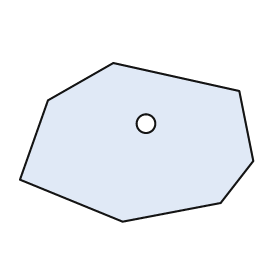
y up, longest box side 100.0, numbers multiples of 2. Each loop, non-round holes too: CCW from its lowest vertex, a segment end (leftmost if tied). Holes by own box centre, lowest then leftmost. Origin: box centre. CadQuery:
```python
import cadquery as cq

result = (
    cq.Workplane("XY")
    .moveTo(-6.0, -34.0)
    .lineTo(36.0, -26.0)
    .lineTo(50.0, -8.0)
    .lineTo(44.0, 22.0)
    .lineTo(-10.0, 34.0)
    .lineTo(-38.0, 18.0)
    .lineTo(-50.0, -16.0)
    .close()
    .moveTo(4.0, 8.0)
    .circle(4.0)
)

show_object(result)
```